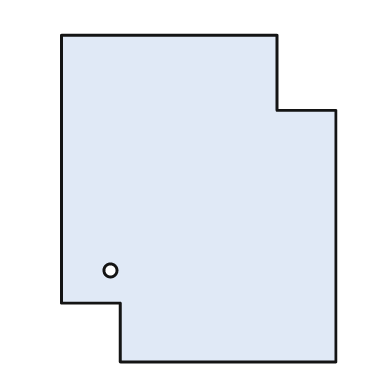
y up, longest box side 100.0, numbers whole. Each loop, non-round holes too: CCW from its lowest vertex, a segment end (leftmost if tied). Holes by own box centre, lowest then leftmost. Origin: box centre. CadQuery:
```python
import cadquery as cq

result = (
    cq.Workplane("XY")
    .moveTo(-24.0, -50.0)
    .lineTo(42.0, -50.0)
    .lineTo(42.0, 27.0)
    .lineTo(24.0, 27.0)
    .lineTo(24.0, 50.0)
    .lineTo(-42.0, 50.0)
    .lineTo(-42.0, -32.0)
    .lineTo(-24.0, -32.0)
    .close()
    .moveTo(-27.0, -22.0)
    .circle(2.0)
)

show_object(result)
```